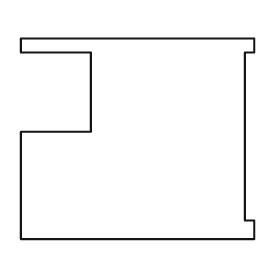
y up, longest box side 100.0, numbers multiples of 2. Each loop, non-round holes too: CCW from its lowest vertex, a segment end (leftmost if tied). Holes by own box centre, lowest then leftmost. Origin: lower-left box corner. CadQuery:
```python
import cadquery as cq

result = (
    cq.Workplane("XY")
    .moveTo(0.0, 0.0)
    .lineTo(100.0, 0.0)
    .lineTo(100.0, 8.0)
    .lineTo(96.0, 8.0)
    .lineTo(96.0, 80.0)
    .lineTo(100.0, 80.0)
    .lineTo(100.0, 86.0)
    .lineTo(0.0, 86.0)
    .lineTo(0.0, 80.0)
    .lineTo(30.0, 80.0)
    .lineTo(30.0, 46.0)
    .lineTo(0.0, 46.0)
    .close()
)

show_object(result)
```